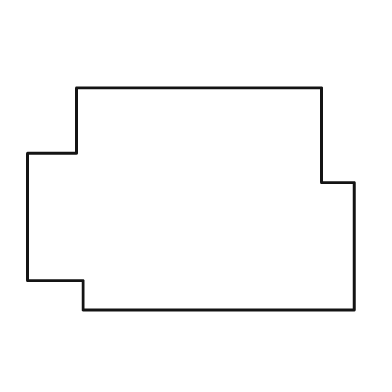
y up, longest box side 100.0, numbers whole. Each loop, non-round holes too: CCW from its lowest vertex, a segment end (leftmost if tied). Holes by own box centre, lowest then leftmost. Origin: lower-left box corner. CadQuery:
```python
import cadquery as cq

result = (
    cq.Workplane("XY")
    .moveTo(17.0, 0.0)
    .lineTo(100.0, 0.0)
    .lineTo(100.0, 39.0)
    .lineTo(90.0, 39.0)
    .lineTo(90.0, 68.0)
    .lineTo(15.0, 68.0)
    .lineTo(15.0, 48.0)
    .lineTo(0.0, 48.0)
    .lineTo(0.0, 9.0)
    .lineTo(17.0, 9.0)
    .close()
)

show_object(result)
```